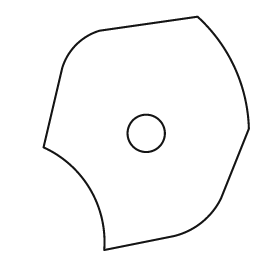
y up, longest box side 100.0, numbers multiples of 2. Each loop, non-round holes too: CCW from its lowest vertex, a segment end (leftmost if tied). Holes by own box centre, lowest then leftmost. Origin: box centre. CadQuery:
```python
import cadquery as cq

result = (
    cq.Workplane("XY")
    .moveTo(-18.0, -50.0)
    .lineTo(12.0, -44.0)
    .threePointArc((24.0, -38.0), (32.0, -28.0))
    .lineTo(44.0, 2.0)
    .threePointArc((38.0, 28.0), (22.0, 50.0))
    .lineTo(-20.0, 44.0)
    .threePointArc((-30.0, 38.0), (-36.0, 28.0))
    .lineTo(-44.0, -6.0)
    .threePointArc((-24.0, -24.0), (-18.0, -50.0))
    .close()
    .moveTo(0.0, 0.0)
    .circle(8.0)
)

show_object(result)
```